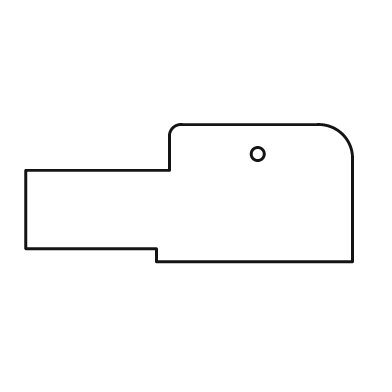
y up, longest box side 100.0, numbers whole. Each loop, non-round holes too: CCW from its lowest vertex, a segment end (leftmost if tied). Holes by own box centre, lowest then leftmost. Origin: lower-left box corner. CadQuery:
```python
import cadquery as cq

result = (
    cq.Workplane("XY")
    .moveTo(40.0, 0.0)
    .lineTo(100.0, 0.0)
    .lineTo(100.0, 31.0)
    .threePointArc((97.0, 39.0), (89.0, 42.0))
    .lineTo(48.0, 42.0)
    .threePointArc((45.0, 41.0), (44.0, 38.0))
    .lineTo(44.0, 28.0)
    .lineTo(0.0, 28.0)
    .lineTo(0.0, 4.0)
    .lineTo(40.0, 4.0)
    .close()
    .moveTo(71.0, 33.0)
    .circle(2.0)
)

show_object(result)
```